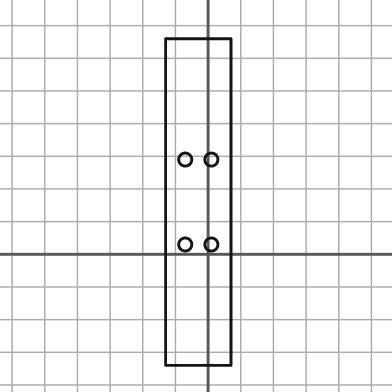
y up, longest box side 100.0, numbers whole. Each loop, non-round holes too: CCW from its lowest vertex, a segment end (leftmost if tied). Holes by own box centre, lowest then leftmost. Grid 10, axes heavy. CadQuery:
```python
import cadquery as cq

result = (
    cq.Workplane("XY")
    .moveTo(-13.0, -34.0)
    .lineTo(7.0, -34.0)
    .lineTo(7.0, 66.0)
    .lineTo(-13.0, 66.0)
    .close()
    .moveTo(-7.0, 3.0)
    .circle(2.0)
    .moveTo(1.0, 3.0)
    .circle(2.0)
    .moveTo(-7.0, 29.0)
    .circle(2.0)
    .moveTo(1.0, 29.0)
    .circle(2.0)
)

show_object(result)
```